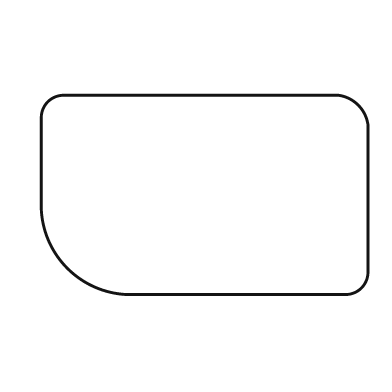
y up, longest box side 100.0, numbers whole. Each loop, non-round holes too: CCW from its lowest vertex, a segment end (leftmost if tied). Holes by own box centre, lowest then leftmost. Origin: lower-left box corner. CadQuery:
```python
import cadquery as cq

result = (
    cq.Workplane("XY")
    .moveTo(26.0, 0.0)
    .lineTo(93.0, 0.0)
    .threePointArc((98.0, 2.0), (100.0, 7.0))
    .lineTo(100.0, 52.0)
    .threePointArc((97.0, 58.0), (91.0, 61.0))
    .lineTo(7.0, 61.0)
    .threePointArc((2.0, 59.0), (0.0, 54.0))
    .lineTo(0.0, 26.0)
    .threePointArc((8.0, 8.0), (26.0, 0.0))
    .close()
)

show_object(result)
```